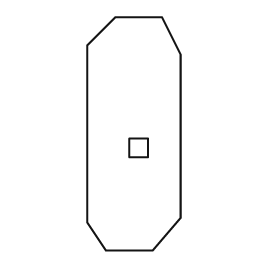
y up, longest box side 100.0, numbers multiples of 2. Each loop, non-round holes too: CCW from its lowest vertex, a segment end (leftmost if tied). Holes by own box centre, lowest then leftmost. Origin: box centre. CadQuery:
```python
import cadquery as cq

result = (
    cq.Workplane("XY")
    .moveTo(-12.0, -50.0)
    .lineTo(8.0, -50.0)
    .lineTo(20.0, -36.0)
    .lineTo(20.0, 34.0)
    .lineTo(12.0, 50.0)
    .lineTo(-8.0, 50.0)
    .lineTo(-20.0, 38.0)
    .lineTo(-20.0, -38.0)
    .close()
    .moveTo(-2.0, -10.0)
    .lineTo(6.0, -10.0)
    .lineTo(6.0, -2.0)
    .lineTo(-2.0, -2.0)
    .close()
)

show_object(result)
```